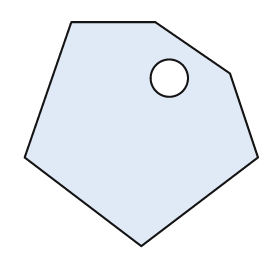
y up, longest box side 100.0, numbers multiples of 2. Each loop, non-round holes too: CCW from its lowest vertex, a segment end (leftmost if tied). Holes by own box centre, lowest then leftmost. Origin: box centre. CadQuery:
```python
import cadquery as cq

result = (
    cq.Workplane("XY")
    .moveTo(0.0, -48.0)
    .lineTo(50.0, -10.0)
    .lineTo(38.0, 26.0)
    .lineTo(6.0, 48.0)
    .lineTo(-30.0, 48.0)
    .lineTo(-50.0, -10.0)
    .close()
    .moveTo(12.0, 24.0)
    .circle(8.0)
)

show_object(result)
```